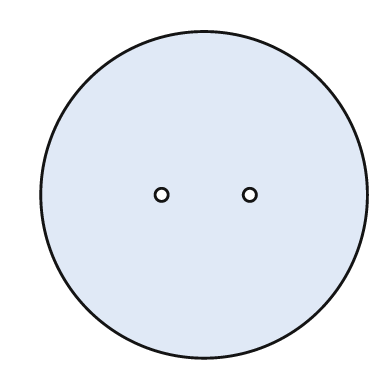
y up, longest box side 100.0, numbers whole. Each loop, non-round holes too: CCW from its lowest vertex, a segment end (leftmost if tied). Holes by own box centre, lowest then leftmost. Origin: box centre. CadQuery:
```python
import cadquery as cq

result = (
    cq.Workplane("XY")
    .moveTo(0.0, 0.0)
    .circle(50.0)
    .moveTo(-13.0, 0.0)
    .circle(2.0)
    .moveTo(14.0, 0.0)
    .circle(2.0)
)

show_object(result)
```